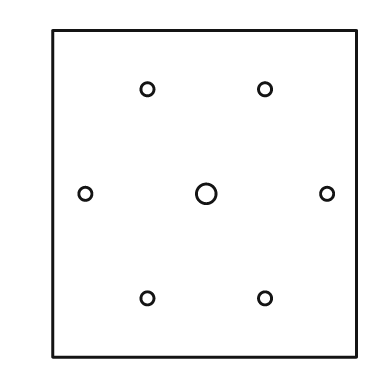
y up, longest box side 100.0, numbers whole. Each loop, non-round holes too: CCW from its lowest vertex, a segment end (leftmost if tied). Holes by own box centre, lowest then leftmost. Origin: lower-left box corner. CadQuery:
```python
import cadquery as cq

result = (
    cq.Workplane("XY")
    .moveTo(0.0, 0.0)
    .lineTo(93.0, 0.0)
    .lineTo(93.0, 100.0)
    .lineTo(0.0, 100.0)
    .close()
    .moveTo(29.0, 18.0)
    .circle(2.0)
    .moveTo(65.0, 18.0)
    .circle(2.0)
    .moveTo(10.0, 50.0)
    .circle(2.0)
    .moveTo(47.0, 50.0)
    .circle(3.0)
    .moveTo(84.0, 50.0)
    .circle(2.0)
    .moveTo(29.0, 82.0)
    .circle(2.0)
    .moveTo(65.0, 82.0)
    .circle(2.0)
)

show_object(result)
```